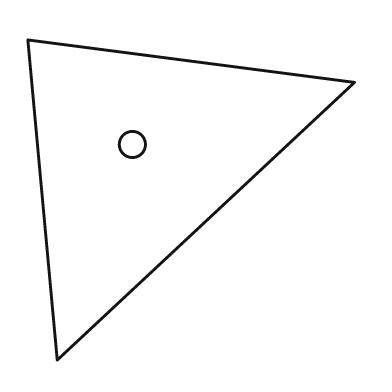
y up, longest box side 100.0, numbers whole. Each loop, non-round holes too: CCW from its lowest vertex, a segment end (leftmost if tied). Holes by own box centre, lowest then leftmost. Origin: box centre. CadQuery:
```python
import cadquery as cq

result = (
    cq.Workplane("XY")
    .moveTo(-41.0, -49.0)
    .lineTo(50.0, 36.0)
    .lineTo(-50.0, 49.0)
    .close()
    .moveTo(-18.0, 17.0)
    .circle(4.0)
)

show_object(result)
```